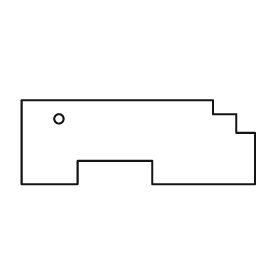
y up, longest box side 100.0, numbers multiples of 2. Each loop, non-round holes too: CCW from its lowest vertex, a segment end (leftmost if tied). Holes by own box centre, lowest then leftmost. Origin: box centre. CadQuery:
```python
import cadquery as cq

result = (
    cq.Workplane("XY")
    .moveTo(-50.0, -18.0)
    .lineTo(-26.0, -18.0)
    .lineTo(-26.0, -8.0)
    .lineTo(6.0, -8.0)
    .lineTo(6.0, -18.0)
    .lineTo(50.0, -18.0)
    .lineTo(50.0, 4.0)
    .lineTo(42.0, 4.0)
    .lineTo(42.0, 12.0)
    .lineTo(32.0, 12.0)
    .lineTo(32.0, 18.0)
    .lineTo(-50.0, 18.0)
    .close()
    .moveTo(-34.0, 10.0)
    .circle(2.0)
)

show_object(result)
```